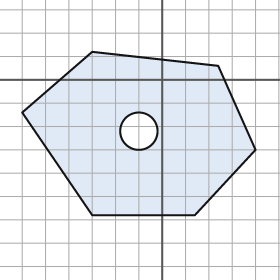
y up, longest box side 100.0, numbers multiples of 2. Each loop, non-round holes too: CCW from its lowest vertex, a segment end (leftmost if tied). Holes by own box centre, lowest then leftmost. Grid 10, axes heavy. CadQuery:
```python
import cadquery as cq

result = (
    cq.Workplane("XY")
    .moveTo(-30.0, -58.0)
    .lineTo(14.0, -58.0)
    .lineTo(40.0, -30.0)
    .lineTo(24.0, 6.0)
    .lineTo(-30.0, 12.0)
    .lineTo(-60.0, -14.0)
    .close()
    .moveTo(-10.0, -22.0)
    .circle(8.0)
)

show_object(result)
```